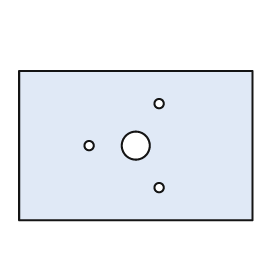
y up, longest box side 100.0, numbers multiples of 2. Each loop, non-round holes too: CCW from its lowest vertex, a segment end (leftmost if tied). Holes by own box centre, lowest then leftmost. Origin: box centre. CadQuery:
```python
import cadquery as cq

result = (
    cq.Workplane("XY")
    .moveTo(-50.0, -32.0)
    .lineTo(50.0, -32.0)
    .lineTo(50.0, 32.0)
    .lineTo(-50.0, 32.0)
    .close()
    .moveTo(10.0, -18.0)
    .circle(2.0)
    .moveTo(-20.0, 0.0)
    .circle(2.0)
    .moveTo(0.0, 0.0)
    .circle(6.0)
    .moveTo(10.0, 18.0)
    .circle(2.0)
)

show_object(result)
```